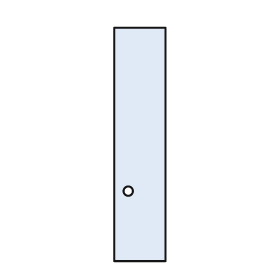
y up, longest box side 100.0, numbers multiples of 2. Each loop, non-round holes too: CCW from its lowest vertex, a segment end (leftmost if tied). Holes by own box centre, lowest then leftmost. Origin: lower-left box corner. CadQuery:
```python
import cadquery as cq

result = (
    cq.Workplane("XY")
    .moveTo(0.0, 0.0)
    .lineTo(22.0, 0.0)
    .lineTo(22.0, 100.0)
    .lineTo(0.0, 100.0)
    .close()
    .moveTo(6.0, 30.0)
    .circle(2.0)
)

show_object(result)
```